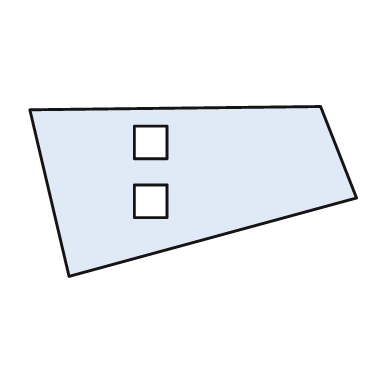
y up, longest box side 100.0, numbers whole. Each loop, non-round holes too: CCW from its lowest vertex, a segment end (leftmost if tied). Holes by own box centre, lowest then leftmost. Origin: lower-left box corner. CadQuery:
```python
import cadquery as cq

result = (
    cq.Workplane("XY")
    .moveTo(12.0, 0.0)
    .lineTo(100.0, 24.0)
    .lineTo(89.0, 52.0)
    .lineTo(0.0, 51.0)
    .close()
    .moveTo(32.0, 18.0)
    .lineTo(42.0, 18.0)
    .lineTo(42.0, 28.0)
    .lineTo(32.0, 28.0)
    .close()
    .moveTo(32.0, 36.0)
    .lineTo(42.0, 36.0)
    .lineTo(42.0, 46.0)
    .lineTo(32.0, 46.0)
    .close()
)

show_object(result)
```